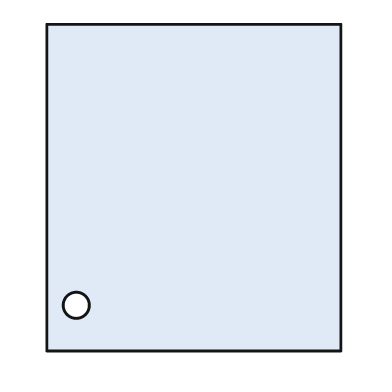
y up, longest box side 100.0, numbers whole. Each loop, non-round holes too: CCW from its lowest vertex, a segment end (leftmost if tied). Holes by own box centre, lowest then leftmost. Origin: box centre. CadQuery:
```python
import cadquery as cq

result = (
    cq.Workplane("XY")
    .moveTo(-45.0, -50.0)
    .lineTo(45.0, -50.0)
    .lineTo(45.0, 50.0)
    .lineTo(-45.0, 50.0)
    .close()
    .moveTo(-36.0, -36.0)
    .circle(4.0)
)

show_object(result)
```